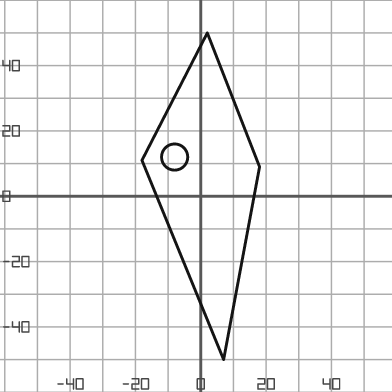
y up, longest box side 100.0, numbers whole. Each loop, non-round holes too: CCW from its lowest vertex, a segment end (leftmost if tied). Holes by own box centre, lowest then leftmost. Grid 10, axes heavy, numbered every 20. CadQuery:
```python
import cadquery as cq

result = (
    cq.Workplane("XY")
    .moveTo(7.0, -50.0)
    .lineTo(18.0, 9.0)
    .lineTo(2.0, 50.0)
    .lineTo(-18.0, 11.0)
    .close()
    .moveTo(-8.0, 12.0)
    .circle(4.0)
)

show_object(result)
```